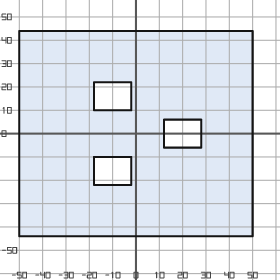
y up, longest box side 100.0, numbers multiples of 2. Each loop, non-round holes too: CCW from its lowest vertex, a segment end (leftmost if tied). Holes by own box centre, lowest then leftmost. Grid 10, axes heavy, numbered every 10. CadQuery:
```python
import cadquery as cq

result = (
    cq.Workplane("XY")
    .moveTo(-50.0, -44.0)
    .lineTo(50.0, -44.0)
    .lineTo(50.0, 44.0)
    .lineTo(-50.0, 44.0)
    .close()
    .moveTo(-18.0, -22.0)
    .lineTo(-2.0, -22.0)
    .lineTo(-2.0, -10.0)
    .lineTo(-18.0, -10.0)
    .close()
    .moveTo(12.0, -6.0)
    .lineTo(28.0, -6.0)
    .lineTo(28.0, 6.0)
    .lineTo(12.0, 6.0)
    .close()
    .moveTo(-18.0, 10.0)
    .lineTo(-2.0, 10.0)
    .lineTo(-2.0, 22.0)
    .lineTo(-18.0, 22.0)
    .close()
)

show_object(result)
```